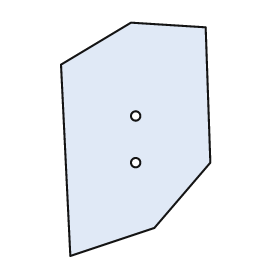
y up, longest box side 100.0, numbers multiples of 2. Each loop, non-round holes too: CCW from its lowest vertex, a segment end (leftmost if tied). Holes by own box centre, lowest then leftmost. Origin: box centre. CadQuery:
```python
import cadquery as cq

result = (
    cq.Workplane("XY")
    .moveTo(-28.0, -50.0)
    .lineTo(8.0, -38.0)
    .lineTo(32.0, -10.0)
    .lineTo(30.0, 48.0)
    .lineTo(-2.0, 50.0)
    .lineTo(-32.0, 32.0)
    .close()
    .moveTo(0.0, -10.0)
    .circle(2.0)
    .moveTo(0.0, 10.0)
    .circle(2.0)
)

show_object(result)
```